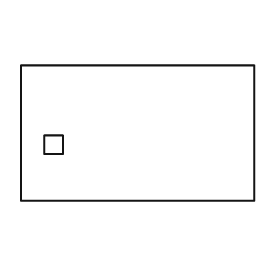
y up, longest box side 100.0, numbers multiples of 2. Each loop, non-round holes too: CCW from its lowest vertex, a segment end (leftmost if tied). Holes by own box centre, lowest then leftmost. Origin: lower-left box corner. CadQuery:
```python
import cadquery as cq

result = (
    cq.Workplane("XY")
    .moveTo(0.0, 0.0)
    .lineTo(100.0, 0.0)
    .lineTo(100.0, 58.0)
    .lineTo(0.0, 58.0)
    .close()
    .moveTo(10.0, 20.0)
    .lineTo(18.0, 20.0)
    .lineTo(18.0, 28.0)
    .lineTo(10.0, 28.0)
    .close()
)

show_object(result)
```